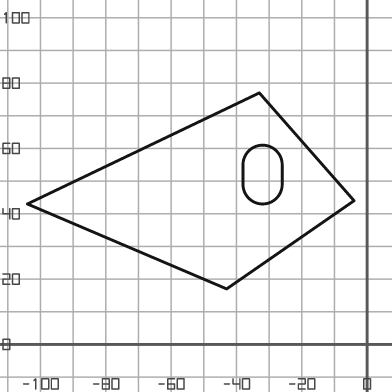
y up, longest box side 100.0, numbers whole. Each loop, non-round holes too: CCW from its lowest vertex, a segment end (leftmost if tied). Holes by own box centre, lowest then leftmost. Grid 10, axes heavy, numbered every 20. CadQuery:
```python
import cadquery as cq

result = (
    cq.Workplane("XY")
    .moveTo(-43.0, 17.0)
    .lineTo(-4.0, 44.0)
    .lineTo(-33.0, 77.0)
    .lineTo(-104.0, 43.0)
    .close()
    .moveTo(-38.0, 49.0)
    .threePointArc((-32.0, 43.0), (-26.0, 49.0))
    .lineTo(-26.0, 55.0)
    .threePointArc((-32.0, 61.0), (-38.0, 55.0))
    .close()
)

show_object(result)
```